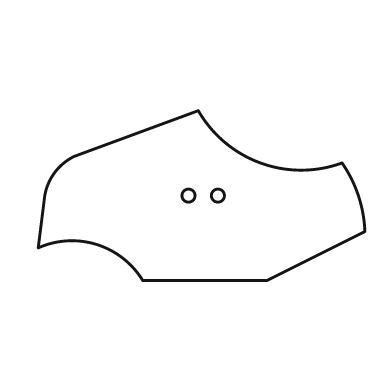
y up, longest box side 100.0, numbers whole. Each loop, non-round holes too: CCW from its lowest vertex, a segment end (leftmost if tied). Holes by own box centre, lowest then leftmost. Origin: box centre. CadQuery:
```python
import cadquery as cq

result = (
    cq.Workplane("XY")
    .moveTo(-18.0, -26.0)
    .lineTo(20.0, -26.0)
    .lineTo(50.0, -11.0)
    .threePointArc((48.0, 0.0), (43.0, 10.0))
    .threePointArc((18.0, 10.0), (-1.0, 26.0))
    .lineTo(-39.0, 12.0)
    .threePointArc((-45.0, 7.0), (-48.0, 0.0))
    .lineTo(-50.0, -16.0)
    .threePointArc((-32.0, -15.0), (-18.0, -26.0))
    .close()
    .moveTo(-4.0, 0.0)
    .circle(2.0)
    .moveTo(5.0, 0.0)
    .circle(2.0)
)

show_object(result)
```